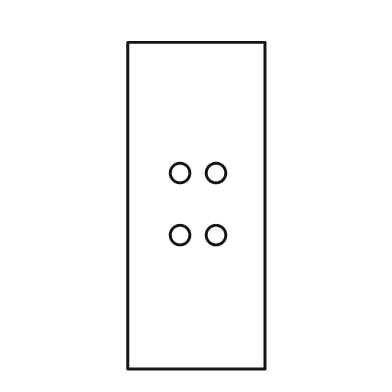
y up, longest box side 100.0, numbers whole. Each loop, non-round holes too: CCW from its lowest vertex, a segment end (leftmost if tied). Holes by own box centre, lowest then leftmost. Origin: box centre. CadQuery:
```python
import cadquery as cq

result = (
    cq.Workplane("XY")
    .moveTo(-21.0, -50.0)
    .lineTo(21.0, -50.0)
    .lineTo(21.0, 50.0)
    .lineTo(-21.0, 50.0)
    .close()
    .moveTo(-5.0, -9.0)
    .circle(3.0)
    .moveTo(6.0, -9.0)
    .circle(3.0)
    .moveTo(-5.0, 10.0)
    .circle(3.0)
    .moveTo(6.0, 10.0)
    .circle(3.0)
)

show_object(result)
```